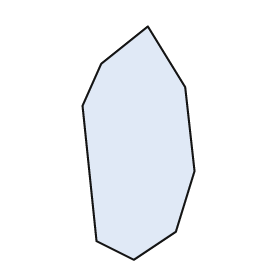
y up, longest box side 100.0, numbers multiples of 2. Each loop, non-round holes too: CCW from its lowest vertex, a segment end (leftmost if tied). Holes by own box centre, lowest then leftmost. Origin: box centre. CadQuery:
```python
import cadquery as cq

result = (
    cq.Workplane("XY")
    .moveTo(-2.0, -50.0)
    .lineTo(16.0, -38.0)
    .lineTo(24.0, -12.0)
    .lineTo(20.0, 24.0)
    .lineTo(4.0, 50.0)
    .lineTo(-16.0, 34.0)
    .lineTo(-24.0, 16.0)
    .lineTo(-18.0, -42.0)
    .close()
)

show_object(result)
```